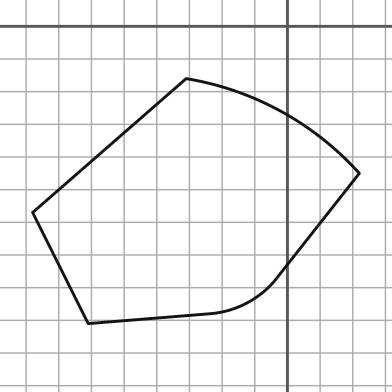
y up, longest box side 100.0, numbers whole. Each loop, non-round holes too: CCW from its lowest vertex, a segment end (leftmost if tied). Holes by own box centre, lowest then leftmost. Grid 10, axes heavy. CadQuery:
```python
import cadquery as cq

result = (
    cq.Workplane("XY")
    .moveTo(-61.0, -91.0)
    .lineTo(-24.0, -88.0)
    .threePointArc((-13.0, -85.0), (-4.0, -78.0))
    .lineTo(22.0, -45.0)
    .threePointArc((-2.0, -26.0), (-31.0, -16.0))
    .lineTo(-78.0, -57.0)
    .close()
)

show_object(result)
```